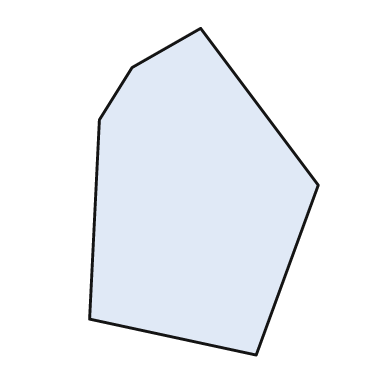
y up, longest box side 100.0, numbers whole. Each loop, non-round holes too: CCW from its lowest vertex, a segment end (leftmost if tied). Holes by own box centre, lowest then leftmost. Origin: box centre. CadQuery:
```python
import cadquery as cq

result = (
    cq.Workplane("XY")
    .moveTo(16.0, -50.0)
    .lineTo(35.0, 2.0)
    .lineTo(-1.0, 50.0)
    .lineTo(-22.0, 38.0)
    .lineTo(-32.0, 22.0)
    .lineTo(-35.0, -39.0)
    .close()
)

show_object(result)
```